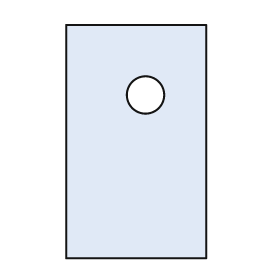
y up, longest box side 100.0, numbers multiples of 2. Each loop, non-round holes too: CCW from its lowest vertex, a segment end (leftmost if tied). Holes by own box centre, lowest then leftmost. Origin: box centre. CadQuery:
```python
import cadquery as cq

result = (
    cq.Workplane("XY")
    .moveTo(-30.0, -50.0)
    .lineTo(30.0, -50.0)
    .lineTo(30.0, 50.0)
    .lineTo(-30.0, 50.0)
    .close()
    .moveTo(4.0, 20.0)
    .circle(8.0)
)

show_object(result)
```